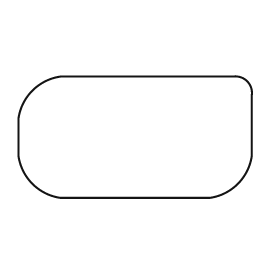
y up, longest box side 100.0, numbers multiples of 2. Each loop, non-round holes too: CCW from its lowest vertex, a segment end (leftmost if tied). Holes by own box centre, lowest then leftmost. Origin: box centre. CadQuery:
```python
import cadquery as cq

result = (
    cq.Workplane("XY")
    .moveTo(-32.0, -26.0)
    .lineTo(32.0, -26.0)
    .threePointArc((44.0, -20.0), (50.0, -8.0))
    .lineTo(50.0, 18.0)
    .threePointArc((48.0, 24.0), (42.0, 26.0))
    .lineTo(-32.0, 26.0)
    .threePointArc((-44.0, 20.0), (-50.0, 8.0))
    .lineTo(-50.0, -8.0)
    .threePointArc((-44.0, -20.0), (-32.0, -26.0))
    .close()
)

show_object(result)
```